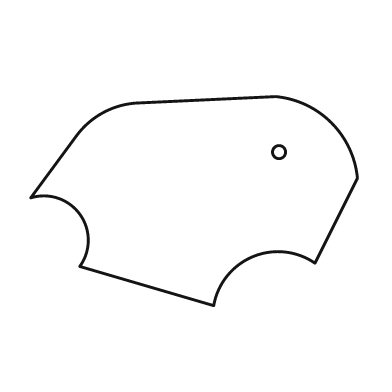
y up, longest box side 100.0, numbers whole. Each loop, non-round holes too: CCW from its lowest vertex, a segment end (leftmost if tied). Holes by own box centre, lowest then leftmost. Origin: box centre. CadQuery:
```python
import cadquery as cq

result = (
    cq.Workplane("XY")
    .moveTo(6.0, -32.0)
    .threePointArc((18.0, -17.0), (37.0, -19.0))
    .lineTo(50.0, 7.0)
    .threePointArc((42.0, 24.0), (25.0, 32.0))
    .lineTo(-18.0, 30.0)
    .threePointArc((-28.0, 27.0), (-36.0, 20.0))
    .lineTo(-50.0, 1.0)
    .threePointArc((-35.0, -4.0), (-35.0, -20.0))
    .close()
    .moveTo(26.0, 15.0)
    .circle(2.0)
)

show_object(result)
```